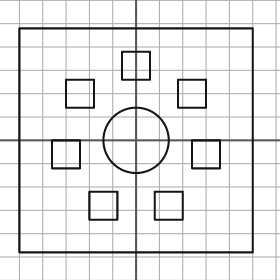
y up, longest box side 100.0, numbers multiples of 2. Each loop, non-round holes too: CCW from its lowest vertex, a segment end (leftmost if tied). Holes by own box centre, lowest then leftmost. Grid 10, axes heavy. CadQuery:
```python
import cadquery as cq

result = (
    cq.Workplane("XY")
    .moveTo(-50.0, -48.0)
    .lineTo(50.0, -48.0)
    .lineTo(50.0, 48.0)
    .lineTo(-50.0, 48.0)
    .close()
    .moveTo(-20.0, -34.0)
    .lineTo(-8.0, -34.0)
    .lineTo(-8.0, -22.0)
    .lineTo(-20.0, -22.0)
    .close()
    .moveTo(8.0, -34.0)
    .lineTo(20.0, -34.0)
    .lineTo(20.0, -22.0)
    .lineTo(8.0, -22.0)
    .close()
    .moveTo(-36.0, -12.0)
    .lineTo(-24.0, -12.0)
    .lineTo(-24.0, 0.0)
    .lineTo(-36.0, 0.0)
    .close()
    .moveTo(24.0, -12.0)
    .lineTo(36.0, -12.0)
    .lineTo(36.0, 0.0)
    .lineTo(24.0, 0.0)
    .close()
    .moveTo(0.0, 0.0)
    .circle(14.0)
    .moveTo(-30.0, 14.0)
    .lineTo(-18.0, 14.0)
    .lineTo(-18.0, 26.0)
    .lineTo(-30.0, 26.0)
    .close()
    .moveTo(18.0, 14.0)
    .lineTo(30.0, 14.0)
    .lineTo(30.0, 26.0)
    .lineTo(18.0, 26.0)
    .close()
    .moveTo(-6.0, 26.0)
    .lineTo(6.0, 26.0)
    .lineTo(6.0, 38.0)
    .lineTo(-6.0, 38.0)
    .close()
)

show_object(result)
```